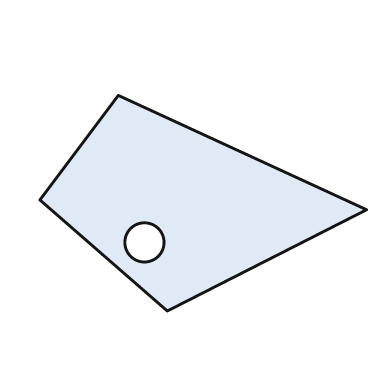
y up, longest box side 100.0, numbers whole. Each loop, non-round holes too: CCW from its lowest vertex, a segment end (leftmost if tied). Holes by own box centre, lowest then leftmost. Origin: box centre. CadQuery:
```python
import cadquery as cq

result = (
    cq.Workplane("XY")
    .moveTo(-11.0, -33.0)
    .lineTo(50.0, -2.0)
    .lineTo(-26.0, 33.0)
    .lineTo(-50.0, 1.0)
    .close()
    .moveTo(-18.0, -12.0)
    .circle(6.0)
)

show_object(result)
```